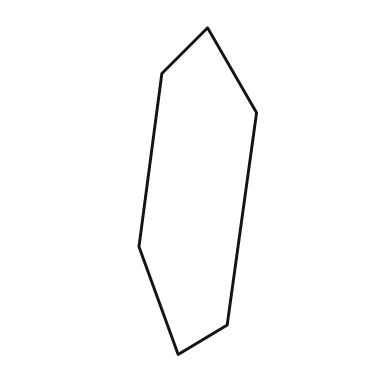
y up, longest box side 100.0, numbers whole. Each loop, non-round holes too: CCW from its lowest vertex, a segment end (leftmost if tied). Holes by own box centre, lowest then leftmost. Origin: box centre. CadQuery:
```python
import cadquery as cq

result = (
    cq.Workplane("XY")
    .moveTo(-6.0, -50.0)
    .lineTo(9.0, -41.0)
    .lineTo(18.0, 24.0)
    .lineTo(3.0, 50.0)
    .lineTo(-11.0, 36.0)
    .lineTo(-18.0, -17.0)
    .close()
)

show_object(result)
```